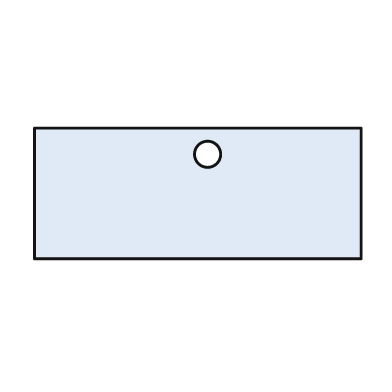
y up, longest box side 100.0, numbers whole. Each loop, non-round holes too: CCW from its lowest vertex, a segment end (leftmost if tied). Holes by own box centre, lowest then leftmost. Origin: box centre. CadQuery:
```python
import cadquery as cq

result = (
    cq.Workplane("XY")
    .moveTo(-50.0, -20.0)
    .lineTo(50.0, -20.0)
    .lineTo(50.0, 20.0)
    .lineTo(-50.0, 20.0)
    .close()
    .moveTo(3.0, 12.0)
    .circle(4.0)
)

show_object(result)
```